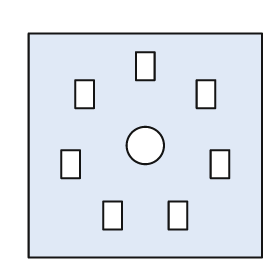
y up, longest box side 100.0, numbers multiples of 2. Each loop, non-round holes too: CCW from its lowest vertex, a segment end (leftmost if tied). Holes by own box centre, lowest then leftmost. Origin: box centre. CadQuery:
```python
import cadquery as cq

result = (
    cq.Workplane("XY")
    .moveTo(-50.0, -48.0)
    .lineTo(50.0, -48.0)
    .lineTo(50.0, 48.0)
    .lineTo(-50.0, 48.0)
    .close()
    .moveTo(-18.0, -36.0)
    .lineTo(-10.0, -36.0)
    .lineTo(-10.0, -24.0)
    .lineTo(-18.0, -24.0)
    .close()
    .moveTo(10.0, -36.0)
    .lineTo(18.0, -36.0)
    .lineTo(18.0, -24.0)
    .lineTo(10.0, -24.0)
    .close()
    .moveTo(-36.0, -14.0)
    .lineTo(-28.0, -14.0)
    .lineTo(-28.0, -2.0)
    .lineTo(-36.0, -2.0)
    .close()
    .moveTo(28.0, -14.0)
    .lineTo(36.0, -14.0)
    .lineTo(36.0, -2.0)
    .lineTo(28.0, -2.0)
    .close()
    .moveTo(0.0, 0.0)
    .circle(8.0)
    .moveTo(-30.0, 16.0)
    .lineTo(-22.0, 16.0)
    .lineTo(-22.0, 28.0)
    .lineTo(-30.0, 28.0)
    .close()
    .moveTo(22.0, 16.0)
    .lineTo(30.0, 16.0)
    .lineTo(30.0, 28.0)
    .lineTo(22.0, 28.0)
    .close()
    .moveTo(-4.0, 28.0)
    .lineTo(4.0, 28.0)
    .lineTo(4.0, 40.0)
    .lineTo(-4.0, 40.0)
    .close()
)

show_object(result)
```